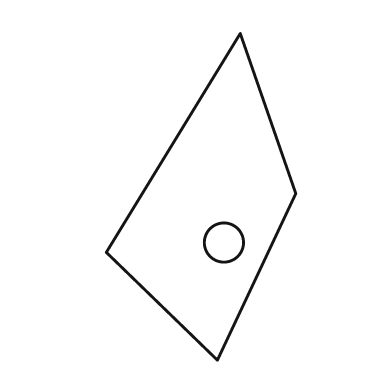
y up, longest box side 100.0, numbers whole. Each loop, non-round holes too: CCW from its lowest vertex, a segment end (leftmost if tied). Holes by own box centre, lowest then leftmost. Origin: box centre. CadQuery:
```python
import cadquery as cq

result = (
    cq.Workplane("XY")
    .moveTo(5.0, -50.0)
    .lineTo(29.0, 1.0)
    .lineTo(12.0, 50.0)
    .lineTo(-29.0, -17.0)
    .close()
    .moveTo(7.0, -14.0)
    .circle(6.0)
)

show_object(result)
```